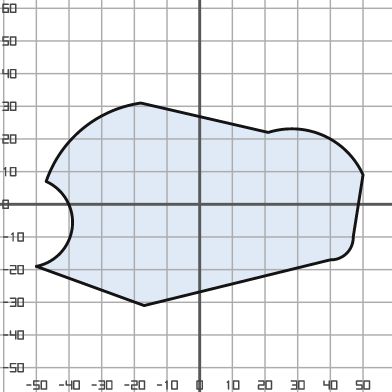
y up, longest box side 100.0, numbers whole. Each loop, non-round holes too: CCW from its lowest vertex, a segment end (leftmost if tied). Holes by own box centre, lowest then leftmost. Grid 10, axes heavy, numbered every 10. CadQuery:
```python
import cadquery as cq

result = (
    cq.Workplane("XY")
    .moveTo(-17.0, -31.0)
    .lineTo(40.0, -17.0)
    .threePointArc((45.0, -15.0), (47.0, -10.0))
    .lineTo(50.0, 9.0)
    .threePointArc((38.0, 21.0), (21.0, 22.0))
    .lineTo(-18.0, 31.0)
    .threePointArc((-36.0, 23.0), (-47.0, 7.0))
    .threePointArc((-39.0, -7.0), (-50.0, -19.0))
    .close()
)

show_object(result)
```